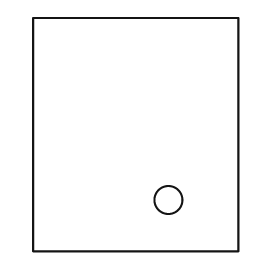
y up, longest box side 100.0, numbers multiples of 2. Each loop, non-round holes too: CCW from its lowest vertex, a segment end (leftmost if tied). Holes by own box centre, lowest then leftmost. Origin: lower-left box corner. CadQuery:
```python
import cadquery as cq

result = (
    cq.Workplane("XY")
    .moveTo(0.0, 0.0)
    .lineTo(88.0, 0.0)
    .lineTo(88.0, 100.0)
    .lineTo(0.0, 100.0)
    .close()
    .moveTo(58.0, 22.0)
    .circle(6.0)
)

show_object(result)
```